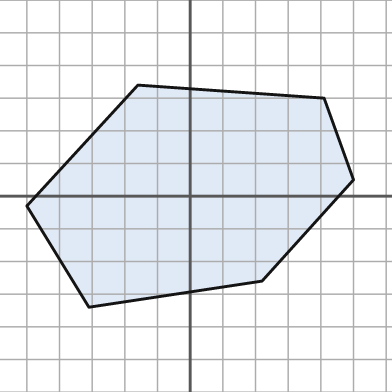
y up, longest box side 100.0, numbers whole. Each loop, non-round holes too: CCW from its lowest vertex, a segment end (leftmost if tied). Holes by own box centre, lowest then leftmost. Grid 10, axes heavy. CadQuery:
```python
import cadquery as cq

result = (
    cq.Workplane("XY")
    .moveTo(-31.0, -34.0)
    .lineTo(22.0, -26.0)
    .lineTo(50.0, 5.0)
    .lineTo(41.0, 30.0)
    .lineTo(-16.0, 34.0)
    .lineTo(-50.0, -3.0)
    .close()
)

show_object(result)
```